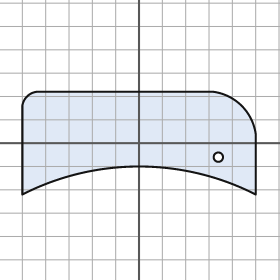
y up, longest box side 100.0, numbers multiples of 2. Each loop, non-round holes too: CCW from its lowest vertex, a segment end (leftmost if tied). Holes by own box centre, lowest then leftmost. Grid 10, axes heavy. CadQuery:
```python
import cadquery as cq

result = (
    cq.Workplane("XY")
    .moveTo(-50.0, -22.0)
    .threePointArc((0.0, -10.0), (50.0, -22.0))
    .lineTo(50.0, 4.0)
    .threePointArc((44.0, 16.0), (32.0, 22.0))
    .lineTo(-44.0, 22.0)
    .threePointArc((-48.0, 20.0), (-50.0, 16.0))
    .close()
    .moveTo(34.0, -6.0)
    .circle(2.0)
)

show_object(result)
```